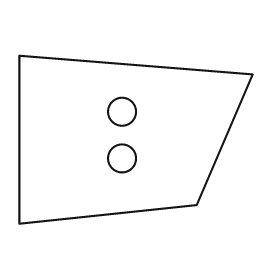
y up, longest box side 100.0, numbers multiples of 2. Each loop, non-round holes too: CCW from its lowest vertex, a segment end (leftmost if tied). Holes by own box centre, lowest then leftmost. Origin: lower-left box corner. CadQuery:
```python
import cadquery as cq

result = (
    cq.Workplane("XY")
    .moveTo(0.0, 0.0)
    .lineTo(76.0, 8.0)
    .lineTo(100.0, 64.0)
    .lineTo(0.0, 72.0)
    .close()
    .moveTo(44.0, 28.0)
    .circle(6.0)
    .moveTo(44.0, 48.0)
    .circle(6.0)
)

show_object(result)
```